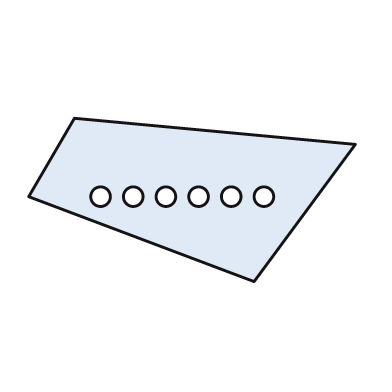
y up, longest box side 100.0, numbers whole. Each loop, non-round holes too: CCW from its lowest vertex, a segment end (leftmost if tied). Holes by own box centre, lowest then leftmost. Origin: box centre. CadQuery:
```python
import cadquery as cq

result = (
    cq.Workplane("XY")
    .moveTo(19.0, -25.0)
    .lineTo(50.0, 17.0)
    .lineTo(-36.0, 25.0)
    .lineTo(-50.0, 1.0)
    .close()
    .moveTo(-28.0, 1.0)
    .circle(3.0)
    .moveTo(-18.0, 1.0)
    .circle(3.0)
    .moveTo(-8.0, 1.0)
    .circle(3.0)
    .moveTo(2.0, 1.0)
    .circle(3.0)
    .moveTo(12.0, 1.0)
    .circle(3.0)
    .moveTo(22.0, 1.0)
    .circle(3.0)
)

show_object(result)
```